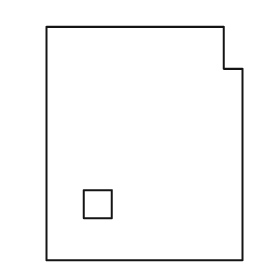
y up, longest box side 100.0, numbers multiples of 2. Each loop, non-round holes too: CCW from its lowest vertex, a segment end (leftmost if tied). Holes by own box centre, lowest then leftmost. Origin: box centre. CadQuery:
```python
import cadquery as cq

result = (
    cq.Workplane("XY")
    .moveTo(-42.0, -50.0)
    .lineTo(42.0, -50.0)
    .lineTo(42.0, 32.0)
    .lineTo(34.0, 32.0)
    .lineTo(34.0, 50.0)
    .lineTo(-42.0, 50.0)
    .close()
    .moveTo(-26.0, -32.0)
    .lineTo(-14.0, -32.0)
    .lineTo(-14.0, -20.0)
    .lineTo(-26.0, -20.0)
    .close()
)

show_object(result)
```